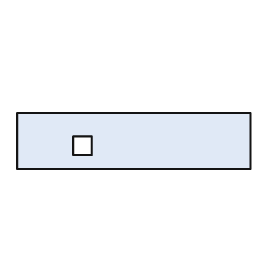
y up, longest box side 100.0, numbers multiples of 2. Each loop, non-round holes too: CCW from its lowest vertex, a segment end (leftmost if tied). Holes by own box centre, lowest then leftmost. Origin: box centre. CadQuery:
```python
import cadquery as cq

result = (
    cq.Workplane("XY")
    .moveTo(-50.0, -12.0)
    .lineTo(50.0, -12.0)
    .lineTo(50.0, 12.0)
    .lineTo(-50.0, 12.0)
    .close()
    .moveTo(-26.0, -6.0)
    .lineTo(-18.0, -6.0)
    .lineTo(-18.0, 2.0)
    .lineTo(-26.0, 2.0)
    .close()
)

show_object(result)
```